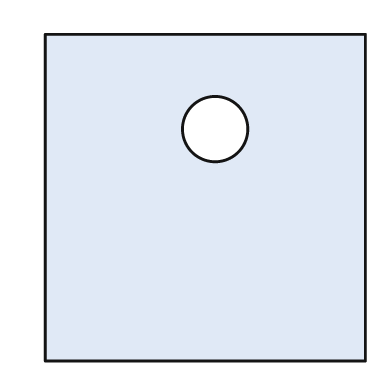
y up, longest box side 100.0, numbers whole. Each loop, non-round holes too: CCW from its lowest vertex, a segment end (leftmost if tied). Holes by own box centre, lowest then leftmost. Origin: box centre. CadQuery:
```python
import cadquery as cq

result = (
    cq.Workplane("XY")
    .moveTo(-49.0, -50.0)
    .lineTo(49.0, -50.0)
    .lineTo(49.0, 50.0)
    .lineTo(-49.0, 50.0)
    .close()
    .moveTo(3.0, 21.0)
    .circle(10.0)
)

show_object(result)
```